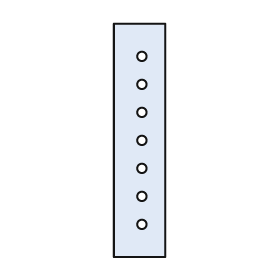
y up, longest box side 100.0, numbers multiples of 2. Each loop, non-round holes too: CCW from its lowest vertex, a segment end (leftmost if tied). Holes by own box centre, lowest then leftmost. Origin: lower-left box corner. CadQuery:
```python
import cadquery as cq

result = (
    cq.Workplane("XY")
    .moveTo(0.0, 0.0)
    .lineTo(22.0, 0.0)
    .lineTo(22.0, 100.0)
    .lineTo(0.0, 100.0)
    .close()
    .moveTo(12.0, 14.0)
    .circle(2.0)
    .moveTo(12.0, 26.0)
    .circle(2.0)
    .moveTo(12.0, 38.0)
    .circle(2.0)
    .moveTo(12.0, 50.0)
    .circle(2.0)
    .moveTo(12.0, 62.0)
    .circle(2.0)
    .moveTo(12.0, 74.0)
    .circle(2.0)
    .moveTo(12.0, 86.0)
    .circle(2.0)
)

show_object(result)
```